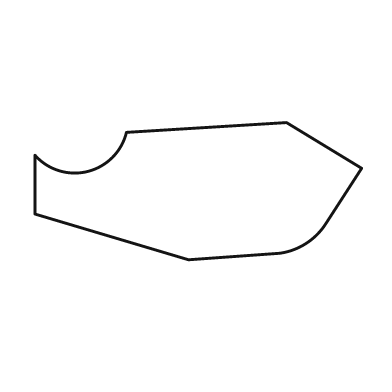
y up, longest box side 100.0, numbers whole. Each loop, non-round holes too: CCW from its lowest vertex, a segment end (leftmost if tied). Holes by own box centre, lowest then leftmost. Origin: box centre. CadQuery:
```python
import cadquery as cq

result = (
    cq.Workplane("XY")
    .moveTo(-3.0, -21.0)
    .lineTo(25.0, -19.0)
    .threePointArc((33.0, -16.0), (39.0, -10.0))
    .lineTo(50.0, 7.0)
    .lineTo(27.0, 21.0)
    .lineTo(-22.0, 18.0)
    .threePointArc((-34.0, 6.0), (-50.0, 11.0))
    .lineTo(-50.0, -7.0)
    .close()
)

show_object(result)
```